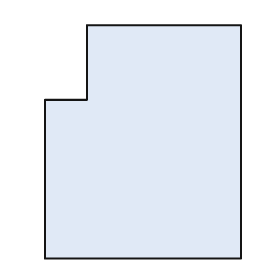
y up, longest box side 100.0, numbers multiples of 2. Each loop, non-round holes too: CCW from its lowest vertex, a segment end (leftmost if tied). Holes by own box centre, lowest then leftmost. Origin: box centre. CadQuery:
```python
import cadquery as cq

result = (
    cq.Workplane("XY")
    .moveTo(-42.0, -50.0)
    .lineTo(42.0, -50.0)
    .lineTo(42.0, 50.0)
    .lineTo(-24.0, 50.0)
    .lineTo(-24.0, 18.0)
    .lineTo(-42.0, 18.0)
    .close()
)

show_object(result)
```